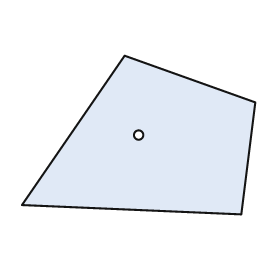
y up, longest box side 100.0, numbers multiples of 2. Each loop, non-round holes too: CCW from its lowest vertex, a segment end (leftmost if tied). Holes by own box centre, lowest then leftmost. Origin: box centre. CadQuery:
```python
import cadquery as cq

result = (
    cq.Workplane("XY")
    .moveTo(44.0, -34.0)
    .lineTo(50.0, 14.0)
    .lineTo(-6.0, 34.0)
    .lineTo(-50.0, -30.0)
    .close()
    .moveTo(0.0, 0.0)
    .circle(2.0)
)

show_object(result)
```